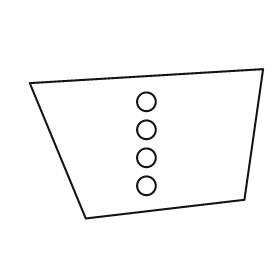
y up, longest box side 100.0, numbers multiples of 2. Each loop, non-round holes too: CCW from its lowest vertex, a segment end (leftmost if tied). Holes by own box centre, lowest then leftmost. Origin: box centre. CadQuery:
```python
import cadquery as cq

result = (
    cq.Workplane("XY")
    .moveTo(-26.0, -32.0)
    .lineTo(42.0, -24.0)
    .lineTo(50.0, 32.0)
    .lineTo(-50.0, 26.0)
    .close()
    .moveTo(0.0, -18.0)
    .circle(4.0)
    .moveTo(0.0, -6.0)
    .circle(4.0)
    .moveTo(0.0, 6.0)
    .circle(4.0)
    .moveTo(0.0, 18.0)
    .circle(4.0)
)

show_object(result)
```